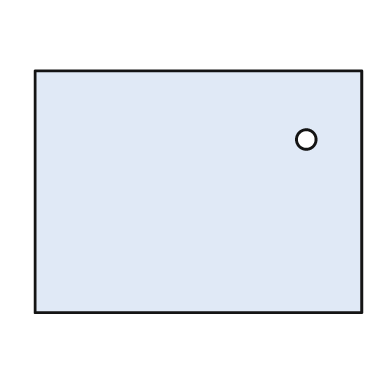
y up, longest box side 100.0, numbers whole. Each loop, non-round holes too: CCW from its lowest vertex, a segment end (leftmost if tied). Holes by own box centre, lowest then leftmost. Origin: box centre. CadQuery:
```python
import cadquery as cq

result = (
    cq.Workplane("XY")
    .moveTo(-50.0, -37.0)
    .lineTo(50.0, -37.0)
    .lineTo(50.0, 37.0)
    .lineTo(-50.0, 37.0)
    .close()
    .moveTo(33.0, 16.0)
    .circle(3.0)
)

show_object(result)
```